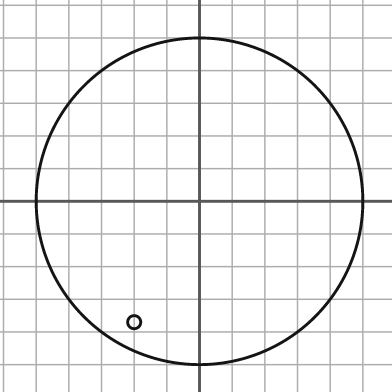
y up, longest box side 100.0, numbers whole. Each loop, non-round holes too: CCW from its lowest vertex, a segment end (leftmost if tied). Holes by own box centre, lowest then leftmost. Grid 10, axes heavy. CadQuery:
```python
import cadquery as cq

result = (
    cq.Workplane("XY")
    .moveTo(0.0, 0.0)
    .circle(50.0)
    .moveTo(-20.0, -37.0)
    .circle(2.0)
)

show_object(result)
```